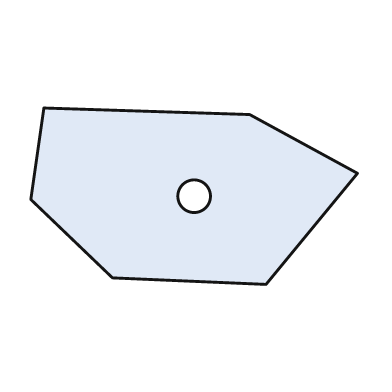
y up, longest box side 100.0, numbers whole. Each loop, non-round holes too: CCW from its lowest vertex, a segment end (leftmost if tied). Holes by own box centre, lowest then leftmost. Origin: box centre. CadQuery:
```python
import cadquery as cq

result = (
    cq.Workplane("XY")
    .moveTo(22.0, -27.0)
    .lineTo(50.0, 7.0)
    .lineTo(17.0, 25.0)
    .lineTo(-46.0, 27.0)
    .lineTo(-50.0, -1.0)
    .lineTo(-25.0, -25.0)
    .close()
    .moveTo(0.0, 0.0)
    .circle(5.0)
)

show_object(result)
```